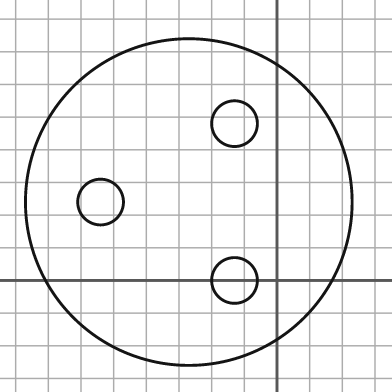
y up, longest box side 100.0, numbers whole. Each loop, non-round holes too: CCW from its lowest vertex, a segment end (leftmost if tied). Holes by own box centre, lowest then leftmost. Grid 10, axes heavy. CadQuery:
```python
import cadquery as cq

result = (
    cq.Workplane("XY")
    .moveTo(-27.0, 24.0)
    .circle(50.0)
    .moveTo(-13.0, 0.0)
    .circle(7.0)
    .moveTo(-54.0, 24.0)
    .circle(7.0)
    .moveTo(-13.0, 48.0)
    .circle(7.0)
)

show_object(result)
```